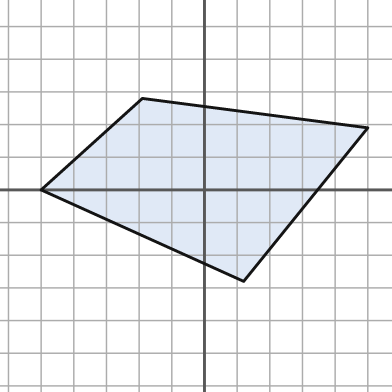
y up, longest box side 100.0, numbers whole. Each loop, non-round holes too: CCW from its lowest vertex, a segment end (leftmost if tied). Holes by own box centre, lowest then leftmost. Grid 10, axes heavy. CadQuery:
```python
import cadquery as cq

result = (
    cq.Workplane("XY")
    .moveTo(12.0, -28.0)
    .lineTo(50.0, 19.0)
    .lineTo(-19.0, 28.0)
    .lineTo(-50.0, 0.0)
    .close()
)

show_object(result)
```